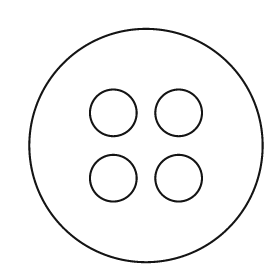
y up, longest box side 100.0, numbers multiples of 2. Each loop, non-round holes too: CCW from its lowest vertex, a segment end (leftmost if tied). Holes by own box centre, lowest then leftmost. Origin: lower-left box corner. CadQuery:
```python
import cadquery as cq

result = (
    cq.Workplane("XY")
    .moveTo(50.0, 50.0)
    .circle(50.0)
    .moveTo(36.0, 36.0)
    .circle(10.0)
    .moveTo(64.0, 36.0)
    .circle(10.0)
    .moveTo(36.0, 64.0)
    .circle(10.0)
    .moveTo(64.0, 64.0)
    .circle(10.0)
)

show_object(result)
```